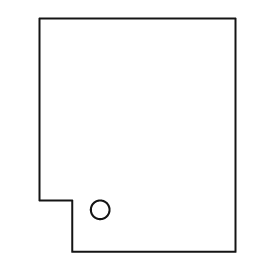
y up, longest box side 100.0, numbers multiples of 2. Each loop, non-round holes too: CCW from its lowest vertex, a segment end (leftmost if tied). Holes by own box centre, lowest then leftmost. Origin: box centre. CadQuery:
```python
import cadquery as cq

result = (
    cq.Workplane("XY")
    .moveTo(-28.0, -50.0)
    .lineTo(42.0, -50.0)
    .lineTo(42.0, 50.0)
    .lineTo(-42.0, 50.0)
    .lineTo(-42.0, -28.0)
    .lineTo(-28.0, -28.0)
    .close()
    .moveTo(-16.0, -32.0)
    .circle(4.0)
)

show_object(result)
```